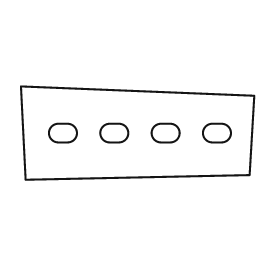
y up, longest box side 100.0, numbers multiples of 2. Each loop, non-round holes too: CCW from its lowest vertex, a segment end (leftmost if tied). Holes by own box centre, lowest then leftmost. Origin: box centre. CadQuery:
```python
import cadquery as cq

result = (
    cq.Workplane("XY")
    .moveTo(-48.0, -20.0)
    .lineTo(48.0, -18.0)
    .lineTo(50.0, 16.0)
    .lineTo(-50.0, 20.0)
    .close()
    .moveTo(-34.0, -4.0)
    .lineTo(-30.0, -4.0)
    .threePointArc((-26.0, 0.0), (-30.0, 4.0))
    .lineTo(-34.0, 4.0)
    .threePointArc((-38.0, 0.0), (-34.0, -4.0))
    .close()
    .moveTo(-12.0, -4.0)
    .lineTo(-8.0, -4.0)
    .threePointArc((-4.0, 0.0), (-8.0, 4.0))
    .lineTo(-12.0, 4.0)
    .threePointArc((-16.0, 0.0), (-12.0, -4.0))
    .close()
    .moveTo(10.0, -4.0)
    .lineTo(14.0, -4.0)
    .threePointArc((18.0, 0.0), (14.0, 4.0))
    .lineTo(10.0, 4.0)
    .threePointArc((6.0, 0.0), (10.0, -4.0))
    .close()
    .moveTo(32.0, -4.0)
    .lineTo(36.0, -4.0)
    .threePointArc((40.0, 0.0), (36.0, 4.0))
    .lineTo(32.0, 4.0)
    .threePointArc((28.0, 0.0), (32.0, -4.0))
    .close()
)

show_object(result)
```